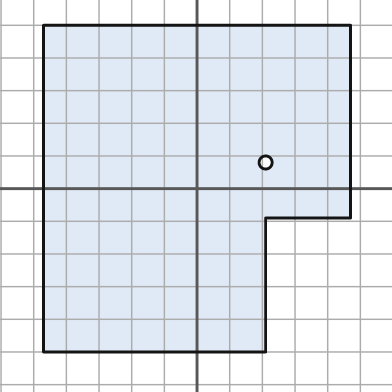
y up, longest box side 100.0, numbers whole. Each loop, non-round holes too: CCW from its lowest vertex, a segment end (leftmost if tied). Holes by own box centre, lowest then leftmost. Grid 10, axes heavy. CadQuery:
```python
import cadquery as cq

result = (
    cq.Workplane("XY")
    .moveTo(-47.0, -50.0)
    .lineTo(21.0, -50.0)
    .lineTo(21.0, -9.0)
    .lineTo(47.0, -9.0)
    .lineTo(47.0, 50.0)
    .lineTo(-47.0, 50.0)
    .close()
    .moveTo(21.0, 8.0)
    .circle(2.0)
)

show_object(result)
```